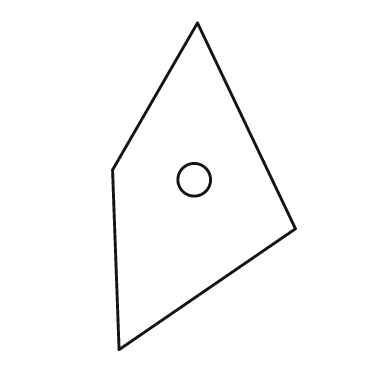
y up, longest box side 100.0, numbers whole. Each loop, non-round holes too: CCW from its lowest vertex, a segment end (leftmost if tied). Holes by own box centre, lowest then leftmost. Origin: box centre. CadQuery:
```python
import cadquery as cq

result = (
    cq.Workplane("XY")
    .moveTo(-26.0, -50.0)
    .lineTo(28.0, -13.0)
    .lineTo(-2.0, 50.0)
    .lineTo(-28.0, 5.0)
    .close()
    .moveTo(-3.0, 2.0)
    .circle(5.0)
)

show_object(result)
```